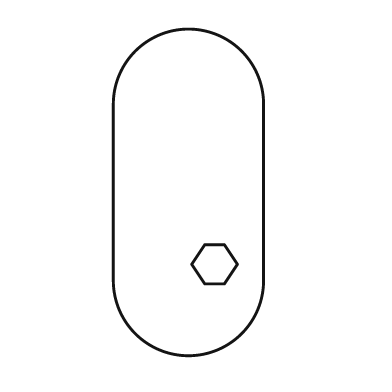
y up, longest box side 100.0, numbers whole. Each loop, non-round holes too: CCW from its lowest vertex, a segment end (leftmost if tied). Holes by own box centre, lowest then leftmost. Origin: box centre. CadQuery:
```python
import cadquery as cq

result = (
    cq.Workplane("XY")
    .moveTo(-23.0, -27.0)
    .threePointArc((0.0, -50.0), (23.0, -27.0))
    .lineTo(23.0, 27.0)
    .threePointArc((0.0, 50.0), (-23.0, 27.0))
    .close()
    .moveTo(5.0, -28.0)
    .lineTo(11.0, -28.0)
    .lineTo(15.0, -22.0)
    .lineTo(11.0, -16.0)
    .lineTo(5.0, -16.0)
    .lineTo(1.0, -22.0)
    .close()
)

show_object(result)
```